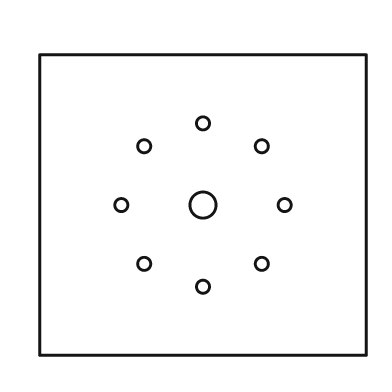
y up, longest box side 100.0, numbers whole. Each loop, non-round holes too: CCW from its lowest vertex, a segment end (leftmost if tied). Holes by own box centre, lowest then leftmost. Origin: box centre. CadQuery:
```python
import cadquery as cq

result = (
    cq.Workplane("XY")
    .moveTo(-50.0, -46.0)
    .lineTo(50.0, -46.0)
    .lineTo(50.0, 46.0)
    .lineTo(-50.0, 46.0)
    .close()
    .moveTo(0.0, -25.0)
    .circle(2.0)
    .moveTo(-18.0, -18.0)
    .circle(2.0)
    .moveTo(18.0, -18.0)
    .circle(2.0)
    .moveTo(-25.0, 0.0)
    .circle(2.0)
    .moveTo(0.0, 0.0)
    .circle(4.0)
    .moveTo(25.0, 0.0)
    .circle(2.0)
    .moveTo(-18.0, 18.0)
    .circle(2.0)
    .moveTo(18.0, 18.0)
    .circle(2.0)
    .moveTo(0.0, 25.0)
    .circle(2.0)
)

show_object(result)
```